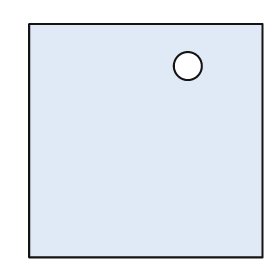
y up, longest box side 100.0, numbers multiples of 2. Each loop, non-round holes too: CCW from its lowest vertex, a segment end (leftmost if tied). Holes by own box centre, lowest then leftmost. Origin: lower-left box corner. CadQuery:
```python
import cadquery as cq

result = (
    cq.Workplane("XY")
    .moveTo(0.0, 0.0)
    .lineTo(100.0, 0.0)
    .lineTo(100.0, 100.0)
    .lineTo(0.0, 100.0)
    .close()
    .moveTo(68.0, 82.0)
    .circle(6.0)
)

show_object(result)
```